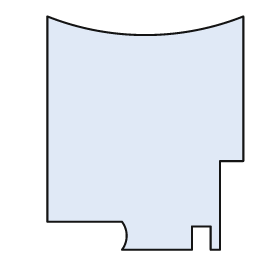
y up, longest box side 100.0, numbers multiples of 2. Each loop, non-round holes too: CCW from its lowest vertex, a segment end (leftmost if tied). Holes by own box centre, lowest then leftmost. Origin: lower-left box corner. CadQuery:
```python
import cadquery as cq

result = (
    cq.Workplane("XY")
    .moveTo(32.0, 0.0)
    .lineTo(62.0, 0.0)
    .lineTo(62.0, 10.0)
    .lineTo(70.0, 10.0)
    .lineTo(70.0, 0.0)
    .lineTo(74.0, 0.0)
    .lineTo(74.0, 38.0)
    .lineTo(84.0, 38.0)
    .lineTo(84.0, 100.0)
    .threePointArc((42.0, 92.0), (0.0, 100.0))
    .lineTo(0.0, 12.0)
    .lineTo(32.0, 12.0)
    .threePointArc((34.0, 6.0), (32.0, 0.0))
    .close()
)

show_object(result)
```